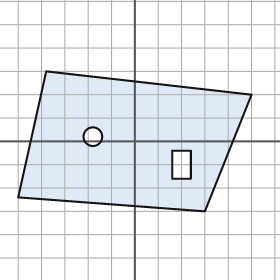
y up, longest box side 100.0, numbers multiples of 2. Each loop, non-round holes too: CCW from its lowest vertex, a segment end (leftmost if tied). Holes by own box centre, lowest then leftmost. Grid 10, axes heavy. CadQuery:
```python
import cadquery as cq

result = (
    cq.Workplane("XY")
    .moveTo(30.0, -30.0)
    .lineTo(50.0, 20.0)
    .lineTo(-38.0, 30.0)
    .lineTo(-50.0, -24.0)
    .close()
    .moveTo(16.0, -16.0)
    .lineTo(24.0, -16.0)
    .lineTo(24.0, -4.0)
    .lineTo(16.0, -4.0)
    .close()
    .moveTo(-18.0, 2.0)
    .circle(4.0)
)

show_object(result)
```